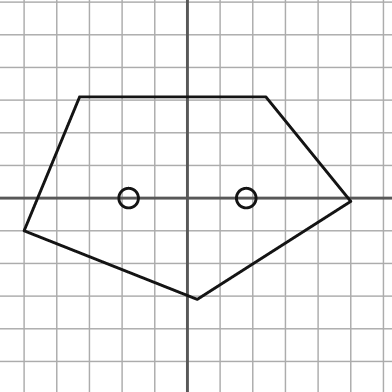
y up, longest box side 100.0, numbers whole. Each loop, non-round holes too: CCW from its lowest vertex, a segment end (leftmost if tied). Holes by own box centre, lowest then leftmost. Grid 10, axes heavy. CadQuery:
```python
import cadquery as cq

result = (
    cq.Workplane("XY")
    .moveTo(3.0, -31.0)
    .lineTo(50.0, -1.0)
    .lineTo(24.0, 31.0)
    .lineTo(-33.0, 31.0)
    .lineTo(-50.0, -10.0)
    .close()
    .moveTo(-18.0, 0.0)
    .circle(3.0)
    .moveTo(18.0, 0.0)
    .circle(3.0)
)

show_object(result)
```